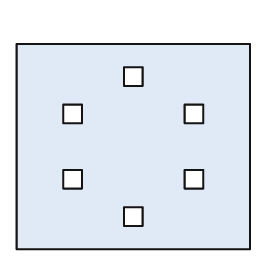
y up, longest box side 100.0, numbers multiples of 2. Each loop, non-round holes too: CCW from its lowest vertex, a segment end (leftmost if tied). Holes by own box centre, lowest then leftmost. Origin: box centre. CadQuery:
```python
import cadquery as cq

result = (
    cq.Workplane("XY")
    .moveTo(-50.0, -44.0)
    .lineTo(50.0, -44.0)
    .lineTo(50.0, 44.0)
    .lineTo(-50.0, 44.0)
    .close()
    .moveTo(-4.0, -34.0)
    .lineTo(4.0, -34.0)
    .lineTo(4.0, -26.0)
    .lineTo(-4.0, -26.0)
    .close()
    .moveTo(-30.0, -18.0)
    .lineTo(-22.0, -18.0)
    .lineTo(-22.0, -10.0)
    .lineTo(-30.0, -10.0)
    .close()
    .moveTo(22.0, -18.0)
    .lineTo(30.0, -18.0)
    .lineTo(30.0, -10.0)
    .lineTo(22.0, -10.0)
    .close()
    .moveTo(-30.0, 10.0)
    .lineTo(-22.0, 10.0)
    .lineTo(-22.0, 18.0)
    .lineTo(-30.0, 18.0)
    .close()
    .moveTo(22.0, 10.0)
    .lineTo(30.0, 10.0)
    .lineTo(30.0, 18.0)
    .lineTo(22.0, 18.0)
    .close()
    .moveTo(-4.0, 26.0)
    .lineTo(4.0, 26.0)
    .lineTo(4.0, 34.0)
    .lineTo(-4.0, 34.0)
    .close()
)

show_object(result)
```